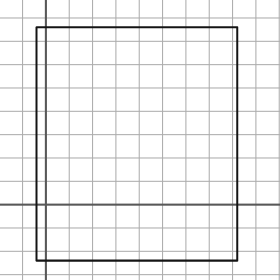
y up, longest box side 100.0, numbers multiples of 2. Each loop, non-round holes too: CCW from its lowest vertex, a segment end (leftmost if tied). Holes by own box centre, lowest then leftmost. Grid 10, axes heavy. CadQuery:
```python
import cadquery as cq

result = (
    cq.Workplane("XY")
    .moveTo(-4.0, -24.0)
    .lineTo(82.0, -24.0)
    .lineTo(82.0, 76.0)
    .lineTo(-4.0, 76.0)
    .close()
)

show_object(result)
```